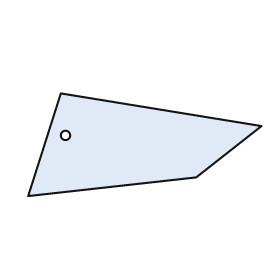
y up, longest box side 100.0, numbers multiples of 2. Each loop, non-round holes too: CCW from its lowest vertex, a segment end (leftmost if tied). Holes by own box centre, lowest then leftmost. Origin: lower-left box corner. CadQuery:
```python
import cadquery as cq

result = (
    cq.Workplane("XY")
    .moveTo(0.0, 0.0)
    .lineTo(72.0, 8.0)
    .lineTo(100.0, 30.0)
    .lineTo(14.0, 44.0)
    .close()
    .moveTo(16.0, 26.0)
    .circle(2.0)
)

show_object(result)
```